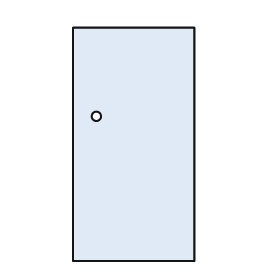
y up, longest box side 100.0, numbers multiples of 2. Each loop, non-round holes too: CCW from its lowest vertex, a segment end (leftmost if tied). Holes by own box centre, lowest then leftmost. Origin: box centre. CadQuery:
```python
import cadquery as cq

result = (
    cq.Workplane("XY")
    .moveTo(-26.0, -50.0)
    .lineTo(26.0, -50.0)
    .lineTo(26.0, 50.0)
    .lineTo(-26.0, 50.0)
    .close()
    .moveTo(-16.0, 12.0)
    .circle(2.0)
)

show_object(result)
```